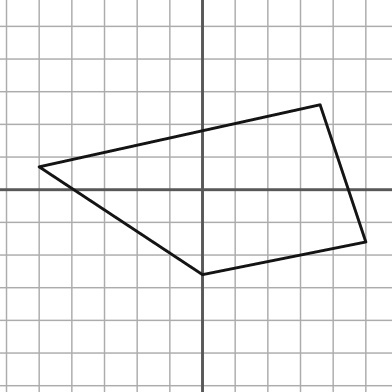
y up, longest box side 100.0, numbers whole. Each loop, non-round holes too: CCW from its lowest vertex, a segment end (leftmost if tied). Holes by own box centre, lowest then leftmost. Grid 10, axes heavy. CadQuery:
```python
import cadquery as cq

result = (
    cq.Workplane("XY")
    .moveTo(0.0, -26.0)
    .lineTo(50.0, -16.0)
    .lineTo(36.0, 26.0)
    .lineTo(-50.0, 7.0)
    .close()
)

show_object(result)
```